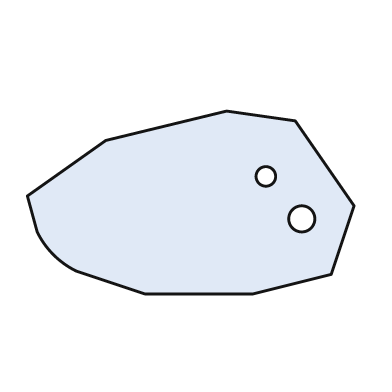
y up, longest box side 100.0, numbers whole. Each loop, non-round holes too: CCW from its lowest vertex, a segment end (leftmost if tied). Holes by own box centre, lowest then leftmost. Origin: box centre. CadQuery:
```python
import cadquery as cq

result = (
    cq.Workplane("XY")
    .moveTo(-14.0, -28.0)
    .lineTo(19.0, -28.0)
    .lineTo(43.0, -22.0)
    .lineTo(50.0, -1.0)
    .lineTo(32.0, 25.0)
    .lineTo(11.0, 28.0)
    .lineTo(-26.0, 19.0)
    .lineTo(-50.0, 2.0)
    .lineTo(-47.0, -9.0)
    .threePointArc((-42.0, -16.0), (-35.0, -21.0))
    .close()
    .moveTo(34.0, -5.0)
    .circle(4.0)
    .moveTo(23.0, 8.0)
    .circle(3.0)
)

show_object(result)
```